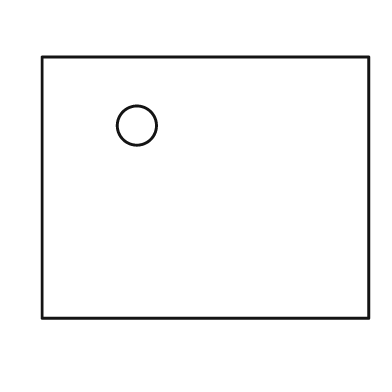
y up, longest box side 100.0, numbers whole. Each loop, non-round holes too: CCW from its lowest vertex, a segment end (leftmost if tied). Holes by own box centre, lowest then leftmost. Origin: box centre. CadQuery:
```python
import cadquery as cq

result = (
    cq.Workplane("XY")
    .moveTo(-50.0, -40.0)
    .lineTo(50.0, -40.0)
    .lineTo(50.0, 40.0)
    .lineTo(-50.0, 40.0)
    .close()
    .moveTo(-21.0, 19.0)
    .circle(6.0)
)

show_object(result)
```